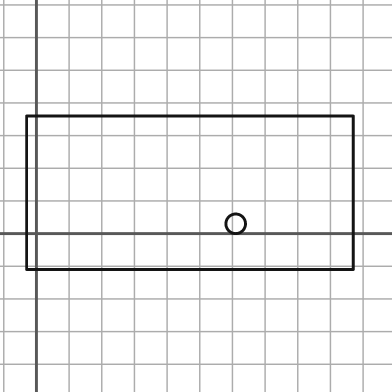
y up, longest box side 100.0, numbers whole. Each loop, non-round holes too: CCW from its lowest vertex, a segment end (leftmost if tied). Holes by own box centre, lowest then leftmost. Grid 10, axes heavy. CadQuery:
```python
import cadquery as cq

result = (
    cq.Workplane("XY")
    .moveTo(-3.0, -11.0)
    .lineTo(97.0, -11.0)
    .lineTo(97.0, 36.0)
    .lineTo(-3.0, 36.0)
    .close()
    .moveTo(61.0, 3.0)
    .circle(3.0)
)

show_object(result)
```